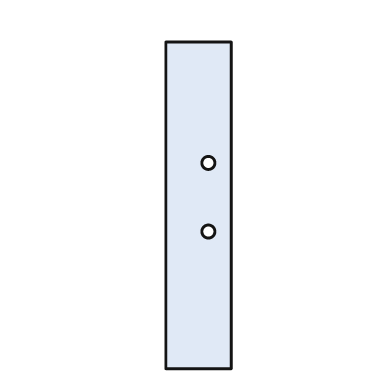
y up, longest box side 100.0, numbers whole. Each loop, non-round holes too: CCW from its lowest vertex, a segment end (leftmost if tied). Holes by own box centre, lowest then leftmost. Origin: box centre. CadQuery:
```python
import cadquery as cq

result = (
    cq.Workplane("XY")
    .moveTo(-10.0, -50.0)
    .lineTo(10.0, -50.0)
    .lineTo(10.0, 50.0)
    .lineTo(-10.0, 50.0)
    .close()
    .moveTo(3.0, -8.0)
    .circle(2.0)
    .moveTo(3.0, 13.0)
    .circle(2.0)
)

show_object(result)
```